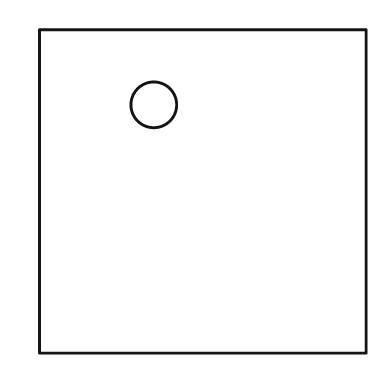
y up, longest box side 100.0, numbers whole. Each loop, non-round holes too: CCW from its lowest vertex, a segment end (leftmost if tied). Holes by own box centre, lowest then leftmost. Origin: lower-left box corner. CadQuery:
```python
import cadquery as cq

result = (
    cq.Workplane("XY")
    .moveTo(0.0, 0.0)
    .lineTo(100.0, 0.0)
    .lineTo(100.0, 99.0)
    .lineTo(0.0, 99.0)
    .close()
    .moveTo(35.0, 76.0)
    .circle(7.0)
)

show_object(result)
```